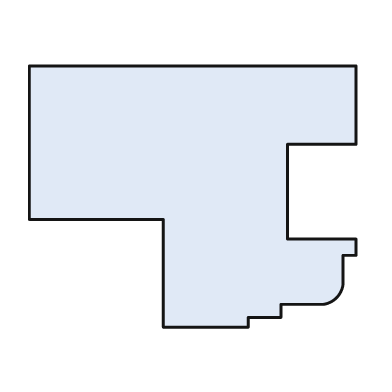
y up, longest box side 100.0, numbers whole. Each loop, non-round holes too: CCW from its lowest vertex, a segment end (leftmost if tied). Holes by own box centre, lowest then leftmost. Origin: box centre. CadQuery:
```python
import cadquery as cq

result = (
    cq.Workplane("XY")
    .moveTo(-9.0, -40.0)
    .lineTo(17.0, -40.0)
    .lineTo(17.0, -37.0)
    .lineTo(27.0, -37.0)
    .lineTo(27.0, -33.0)
    .lineTo(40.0, -33.0)
    .threePointArc((44.0, -31.0), (46.0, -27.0))
    .lineTo(46.0, -18.0)
    .lineTo(50.0, -18.0)
    .lineTo(50.0, -13.0)
    .lineTo(29.0, -13.0)
    .lineTo(29.0, 16.0)
    .lineTo(50.0, 16.0)
    .lineTo(50.0, 40.0)
    .lineTo(-50.0, 40.0)
    .lineTo(-50.0, -7.0)
    .lineTo(-9.0, -7.0)
    .close()
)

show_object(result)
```